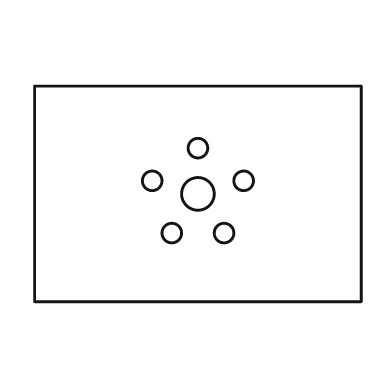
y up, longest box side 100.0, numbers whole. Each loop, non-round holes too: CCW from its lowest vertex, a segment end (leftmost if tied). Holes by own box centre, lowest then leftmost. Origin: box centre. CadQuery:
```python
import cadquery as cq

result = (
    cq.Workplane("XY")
    .moveTo(-50.0, -33.0)
    .lineTo(50.0, -33.0)
    .lineTo(50.0, 33.0)
    .lineTo(-50.0, 33.0)
    .close()
    .moveTo(-8.0, -12.0)
    .circle(3.0)
    .moveTo(8.0, -12.0)
    .circle(3.0)
    .moveTo(0.0, 0.0)
    .circle(5.0)
    .moveTo(-14.0, 4.0)
    .circle(3.0)
    .moveTo(14.0, 4.0)
    .circle(3.0)
    .moveTo(0.0, 14.0)
    .circle(3.0)
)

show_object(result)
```